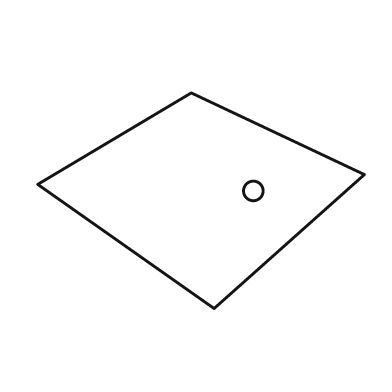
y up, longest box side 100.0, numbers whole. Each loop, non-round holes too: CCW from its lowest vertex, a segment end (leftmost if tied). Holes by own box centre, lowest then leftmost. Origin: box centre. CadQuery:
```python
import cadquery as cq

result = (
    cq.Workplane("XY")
    .moveTo(4.0, -33.0)
    .lineTo(50.0, 8.0)
    .lineTo(-3.0, 33.0)
    .lineTo(-50.0, 5.0)
    .close()
    .moveTo(16.0, 3.0)
    .circle(3.0)
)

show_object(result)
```